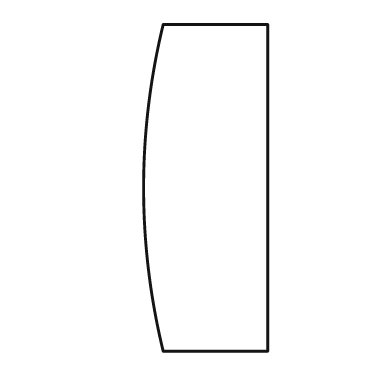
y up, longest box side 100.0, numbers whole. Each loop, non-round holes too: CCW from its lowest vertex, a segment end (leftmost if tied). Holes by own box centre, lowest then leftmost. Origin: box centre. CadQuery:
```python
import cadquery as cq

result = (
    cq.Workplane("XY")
    .moveTo(-13.0, -50.0)
    .lineTo(19.0, -50.0)
    .lineTo(19.0, 50.0)
    .lineTo(-13.0, 50.0)
    .threePointArc((-19.0, 0.0), (-13.0, -50.0))
    .close()
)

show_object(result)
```